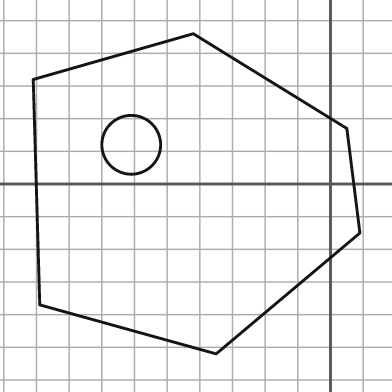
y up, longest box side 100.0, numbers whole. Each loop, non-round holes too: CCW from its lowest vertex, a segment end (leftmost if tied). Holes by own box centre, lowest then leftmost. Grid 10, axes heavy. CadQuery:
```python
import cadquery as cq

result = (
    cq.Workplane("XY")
    .moveTo(-35.0, -52.0)
    .lineTo(9.0, -15.0)
    .lineTo(5.0, 17.0)
    .lineTo(-42.0, 46.0)
    .lineTo(-91.0, 32.0)
    .lineTo(-89.0, -37.0)
    .close()
    .moveTo(-61.0, 12.0)
    .circle(9.0)
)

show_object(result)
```